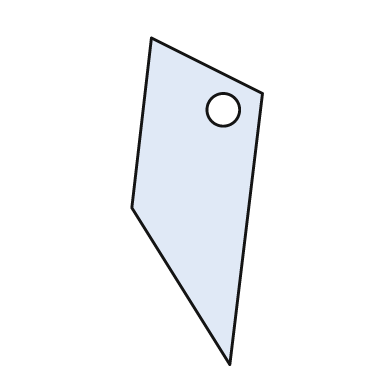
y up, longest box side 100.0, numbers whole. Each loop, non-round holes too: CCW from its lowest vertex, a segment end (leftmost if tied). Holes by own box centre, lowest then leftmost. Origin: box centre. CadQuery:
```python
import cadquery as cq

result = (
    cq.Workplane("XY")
    .moveTo(10.0, -50.0)
    .lineTo(20.0, 33.0)
    .lineTo(-14.0, 50.0)
    .lineTo(-20.0, -2.0)
    .close()
    .moveTo(8.0, 28.0)
    .circle(5.0)
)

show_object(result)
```